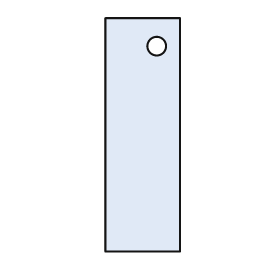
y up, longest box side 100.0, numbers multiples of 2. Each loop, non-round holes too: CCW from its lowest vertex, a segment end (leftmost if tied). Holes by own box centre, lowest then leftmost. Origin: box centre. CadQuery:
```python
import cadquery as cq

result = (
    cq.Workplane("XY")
    .moveTo(-16.0, -50.0)
    .lineTo(16.0, -50.0)
    .lineTo(16.0, 50.0)
    .lineTo(-16.0, 50.0)
    .close()
    .moveTo(6.0, 38.0)
    .circle(4.0)
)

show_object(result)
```